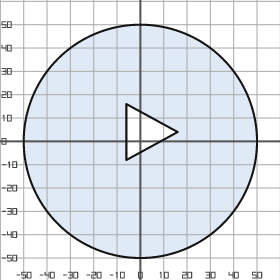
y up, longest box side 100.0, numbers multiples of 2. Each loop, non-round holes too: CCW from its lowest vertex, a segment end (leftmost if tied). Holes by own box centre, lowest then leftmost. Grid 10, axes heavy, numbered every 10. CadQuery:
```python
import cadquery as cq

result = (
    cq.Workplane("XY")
    .moveTo(0.0, 0.0)
    .circle(50.0)
    .moveTo(-6.0, -8.0)
    .lineTo(16.0, 4.0)
    .lineTo(-6.0, 16.0)
    .close()
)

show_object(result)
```